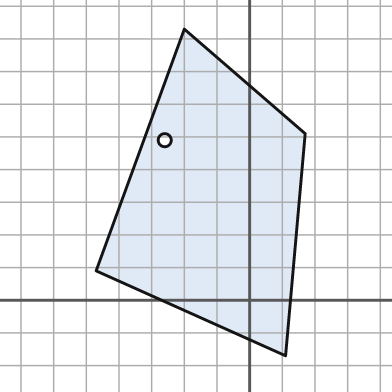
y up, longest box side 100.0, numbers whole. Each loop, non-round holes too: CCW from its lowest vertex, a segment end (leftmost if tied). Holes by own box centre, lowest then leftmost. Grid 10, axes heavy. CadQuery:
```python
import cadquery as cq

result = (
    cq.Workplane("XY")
    .moveTo(11.0, -17.0)
    .lineTo(17.0, 51.0)
    .lineTo(-20.0, 83.0)
    .lineTo(-47.0, 9.0)
    .close()
    .moveTo(-26.0, 49.0)
    .circle(2.0)
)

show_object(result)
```